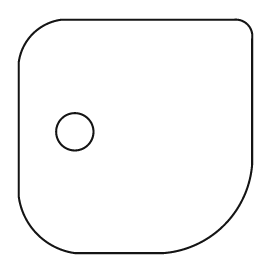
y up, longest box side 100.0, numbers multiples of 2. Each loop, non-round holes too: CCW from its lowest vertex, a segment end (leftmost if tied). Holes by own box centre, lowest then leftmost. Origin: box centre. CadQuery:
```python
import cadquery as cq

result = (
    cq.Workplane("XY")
    .moveTo(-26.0, -50.0)
    .lineTo(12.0, -50.0)
    .threePointArc((38.0, -38.0), (50.0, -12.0))
    .lineTo(50.0, 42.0)
    .threePointArc((48.0, 48.0), (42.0, 50.0))
    .lineTo(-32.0, 50.0)
    .threePointArc((-44.0, 44.0), (-50.0, 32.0))
    .lineTo(-50.0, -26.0)
    .threePointArc((-42.0, -42.0), (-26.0, -50.0))
    .close()
    .moveTo(-26.0, 2.0)
    .circle(8.0)
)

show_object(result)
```